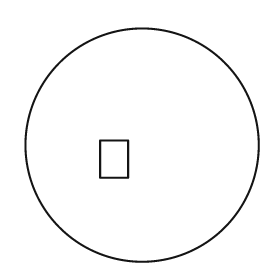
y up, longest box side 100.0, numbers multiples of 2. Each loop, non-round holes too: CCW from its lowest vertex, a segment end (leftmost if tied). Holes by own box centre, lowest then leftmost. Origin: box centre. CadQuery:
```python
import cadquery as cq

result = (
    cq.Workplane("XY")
    .moveTo(0.0, 0.0)
    .circle(50.0)
    .moveTo(-18.0, -14.0)
    .lineTo(-6.0, -14.0)
    .lineTo(-6.0, 2.0)
    .lineTo(-18.0, 2.0)
    .close()
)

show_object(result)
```